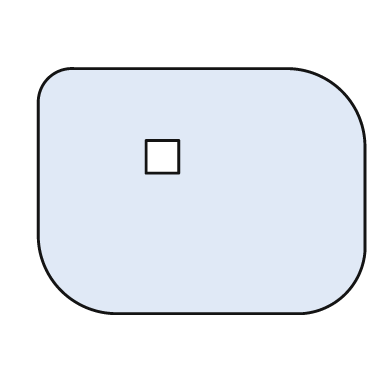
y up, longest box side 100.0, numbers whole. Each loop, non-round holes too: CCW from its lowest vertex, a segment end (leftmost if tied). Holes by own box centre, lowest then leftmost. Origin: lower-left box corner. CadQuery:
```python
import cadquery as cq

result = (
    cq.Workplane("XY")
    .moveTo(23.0, 0.0)
    .lineTo(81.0, 0.0)
    .threePointArc((94.0, 6.0), (100.0, 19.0))
    .lineTo(100.0, 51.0)
    .threePointArc((93.0, 68.0), (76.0, 75.0))
    .lineTo(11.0, 75.0)
    .threePointArc((3.0, 72.0), (0.0, 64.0))
    .lineTo(0.0, 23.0)
    .threePointArc((7.0, 7.0), (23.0, 0.0))
    .close()
    .moveTo(33.0, 43.0)
    .lineTo(43.0, 43.0)
    .lineTo(43.0, 53.0)
    .lineTo(33.0, 53.0)
    .close()
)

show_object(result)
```